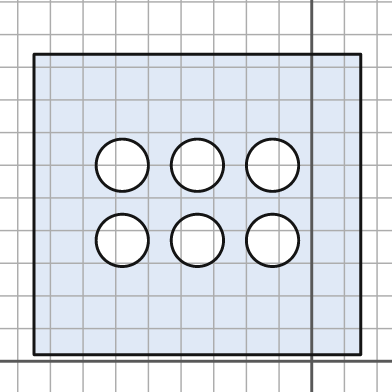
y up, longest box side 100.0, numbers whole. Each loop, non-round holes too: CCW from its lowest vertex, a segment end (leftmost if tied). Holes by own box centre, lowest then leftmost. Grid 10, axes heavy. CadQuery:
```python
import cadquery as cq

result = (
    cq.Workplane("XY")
    .moveTo(-85.0, 2.0)
    .lineTo(15.0, 2.0)
    .lineTo(15.0, 94.0)
    .lineTo(-85.0, 94.0)
    .close()
    .moveTo(-58.0, 37.0)
    .circle(8.0)
    .moveTo(-35.0, 37.0)
    .circle(8.0)
    .moveTo(-12.0, 37.0)
    .circle(8.0)
    .moveTo(-58.0, 60.0)
    .circle(8.0)
    .moveTo(-35.0, 60.0)
    .circle(8.0)
    .moveTo(-12.0, 60.0)
    .circle(8.0)
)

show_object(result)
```